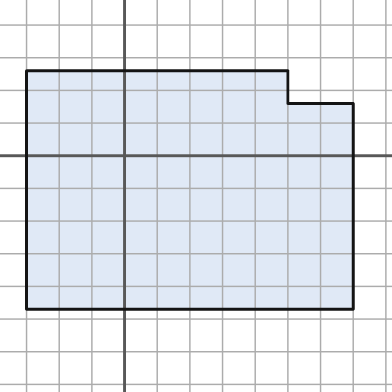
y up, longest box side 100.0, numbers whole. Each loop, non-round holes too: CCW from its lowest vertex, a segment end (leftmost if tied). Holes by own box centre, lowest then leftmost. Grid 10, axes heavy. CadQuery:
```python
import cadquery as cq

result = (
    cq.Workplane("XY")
    .moveTo(-30.0, -47.0)
    .lineTo(70.0, -47.0)
    .lineTo(70.0, 16.0)
    .lineTo(50.0, 16.0)
    .lineTo(50.0, 26.0)
    .lineTo(-30.0, 26.0)
    .close()
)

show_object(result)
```